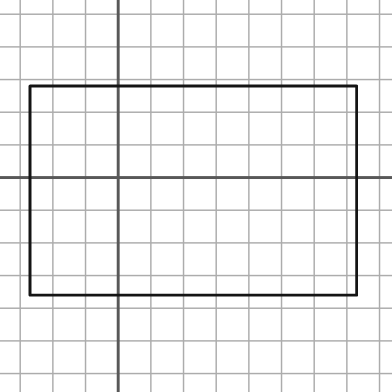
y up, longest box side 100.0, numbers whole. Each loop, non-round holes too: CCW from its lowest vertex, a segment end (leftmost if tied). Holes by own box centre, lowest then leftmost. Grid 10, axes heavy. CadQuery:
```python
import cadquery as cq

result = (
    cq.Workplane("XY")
    .moveTo(-27.0, -36.0)
    .lineTo(73.0, -36.0)
    .lineTo(73.0, 28.0)
    .lineTo(-27.0, 28.0)
    .close()
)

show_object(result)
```